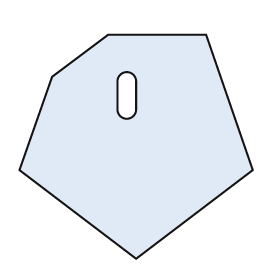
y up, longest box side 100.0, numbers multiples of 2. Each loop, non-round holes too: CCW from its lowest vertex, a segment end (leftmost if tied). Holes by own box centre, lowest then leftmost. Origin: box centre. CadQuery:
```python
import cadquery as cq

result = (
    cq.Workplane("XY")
    .moveTo(0.0, -48.0)
    .lineTo(50.0, -10.0)
    .lineTo(30.0, 48.0)
    .lineTo(-12.0, 48.0)
    .lineTo(-36.0, 30.0)
    .lineTo(-50.0, -10.0)
    .close()
    .moveTo(-8.0, 16.0)
    .threePointArc((-4.0, 12.0), (0.0, 16.0))
    .lineTo(0.0, 28.0)
    .threePointArc((-4.0, 32.0), (-8.0, 28.0))
    .close()
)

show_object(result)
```